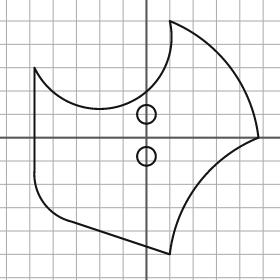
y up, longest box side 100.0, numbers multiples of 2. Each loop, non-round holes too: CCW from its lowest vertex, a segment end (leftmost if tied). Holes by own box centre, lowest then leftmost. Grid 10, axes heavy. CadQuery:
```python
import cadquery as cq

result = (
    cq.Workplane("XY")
    .moveTo(10.0, -50.0)
    .threePointArc((22.0, -20.0), (48.0, 0.0))
    .threePointArc((36.0, 30.0), (10.0, 50.0))
    .threePointArc((-10.0, 14.0), (-48.0, 30.0))
    .lineTo(-48.0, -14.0)
    .threePointArc((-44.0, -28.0), (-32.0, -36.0))
    .close()
    .moveTo(0.0, -8.0)
    .circle(4.0)
    .moveTo(0.0, 10.0)
    .circle(4.0)
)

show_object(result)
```